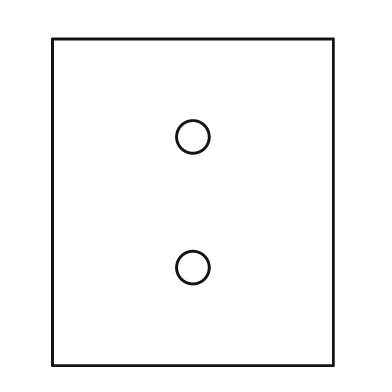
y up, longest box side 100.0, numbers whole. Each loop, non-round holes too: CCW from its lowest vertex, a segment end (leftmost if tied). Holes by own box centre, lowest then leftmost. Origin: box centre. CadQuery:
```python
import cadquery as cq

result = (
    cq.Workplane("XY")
    .moveTo(-43.0, -50.0)
    .lineTo(43.0, -50.0)
    .lineTo(43.0, 50.0)
    .lineTo(-43.0, 50.0)
    .close()
    .moveTo(0.0, -20.0)
    .circle(5.0)
    .moveTo(0.0, 20.0)
    .circle(5.0)
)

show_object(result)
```